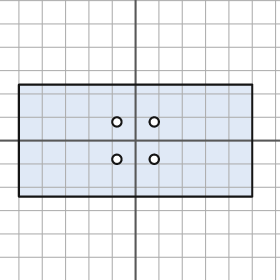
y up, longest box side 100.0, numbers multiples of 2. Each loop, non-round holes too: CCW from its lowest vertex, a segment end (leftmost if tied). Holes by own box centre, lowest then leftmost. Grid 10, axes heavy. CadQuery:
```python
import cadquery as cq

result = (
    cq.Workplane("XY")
    .moveTo(-50.0, -24.0)
    .lineTo(50.0, -24.0)
    .lineTo(50.0, 24.0)
    .lineTo(-50.0, 24.0)
    .close()
    .moveTo(-8.0, -8.0)
    .circle(2.0)
    .moveTo(8.0, -8.0)
    .circle(2.0)
    .moveTo(-8.0, 8.0)
    .circle(2.0)
    .moveTo(8.0, 8.0)
    .circle(2.0)
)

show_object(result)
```